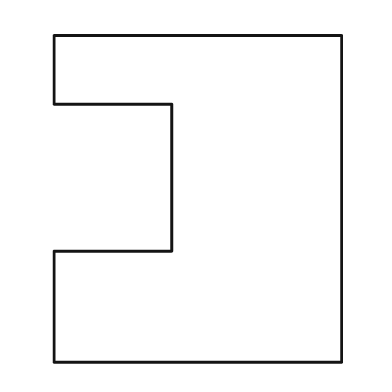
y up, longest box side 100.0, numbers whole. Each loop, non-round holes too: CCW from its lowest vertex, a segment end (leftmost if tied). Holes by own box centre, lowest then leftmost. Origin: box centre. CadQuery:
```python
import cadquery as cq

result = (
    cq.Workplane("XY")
    .moveTo(-44.0, -50.0)
    .lineTo(44.0, -50.0)
    .lineTo(44.0, 50.0)
    .lineTo(-44.0, 50.0)
    .lineTo(-44.0, 29.0)
    .lineTo(-8.0, 29.0)
    .lineTo(-8.0, -16.0)
    .lineTo(-44.0, -16.0)
    .close()
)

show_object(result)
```